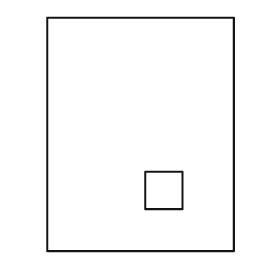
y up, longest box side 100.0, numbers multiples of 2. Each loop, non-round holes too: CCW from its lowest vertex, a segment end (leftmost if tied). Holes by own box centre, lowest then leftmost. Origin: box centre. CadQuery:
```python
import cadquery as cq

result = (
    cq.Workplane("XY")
    .moveTo(-40.0, -50.0)
    .lineTo(40.0, -50.0)
    .lineTo(40.0, 50.0)
    .lineTo(-40.0, 50.0)
    .close()
    .moveTo(2.0, -32.0)
    .lineTo(18.0, -32.0)
    .lineTo(18.0, -16.0)
    .lineTo(2.0, -16.0)
    .close()
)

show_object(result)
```